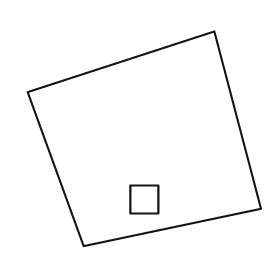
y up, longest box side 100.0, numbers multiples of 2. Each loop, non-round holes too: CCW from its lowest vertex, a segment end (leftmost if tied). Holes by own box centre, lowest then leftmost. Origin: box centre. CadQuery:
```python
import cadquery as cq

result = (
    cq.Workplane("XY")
    .moveTo(-26.0, -46.0)
    .lineTo(50.0, -30.0)
    .lineTo(30.0, 46.0)
    .lineTo(-50.0, 20.0)
    .close()
    .moveTo(-6.0, -32.0)
    .lineTo(6.0, -32.0)
    .lineTo(6.0, -20.0)
    .lineTo(-6.0, -20.0)
    .close()
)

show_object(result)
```